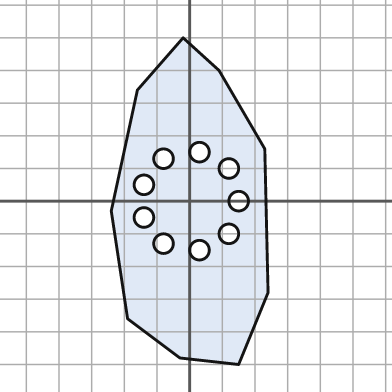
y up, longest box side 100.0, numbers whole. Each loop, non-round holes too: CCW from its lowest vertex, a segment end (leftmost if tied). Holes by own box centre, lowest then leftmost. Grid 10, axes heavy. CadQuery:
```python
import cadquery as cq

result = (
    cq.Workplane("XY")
    .moveTo(15.0, -50.0)
    .lineTo(24.0, -28.0)
    .lineTo(23.0, 16.0)
    .lineTo(9.0, 40.0)
    .lineTo(-2.0, 50.0)
    .lineTo(-16.0, 34.0)
    .lineTo(-24.0, -3.0)
    .lineTo(-19.0, -36.0)
    .lineTo(-3.0, -48.0)
    .close()
    .moveTo(3.0, -15.0)
    .circle(3.0)
    .moveTo(-8.0, -13.0)
    .circle(3.0)
    .moveTo(12.0, -10.0)
    .circle(3.0)
    .moveTo(-14.0, -5.0)
    .circle(3.0)
    .moveTo(15.0, 0.0)
    .circle(3.0)
    .moveTo(-14.0, 5.0)
    .circle(3.0)
    .moveTo(12.0, 10.0)
    .circle(3.0)
    .moveTo(-8.0, 13.0)
    .circle(3.0)
    .moveTo(3.0, 15.0)
    .circle(3.0)
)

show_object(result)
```